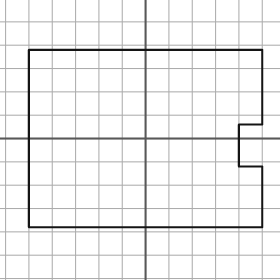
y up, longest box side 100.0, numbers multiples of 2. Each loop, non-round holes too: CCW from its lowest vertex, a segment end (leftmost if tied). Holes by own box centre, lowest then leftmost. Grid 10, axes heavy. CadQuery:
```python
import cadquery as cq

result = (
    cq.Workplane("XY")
    .moveTo(-50.0, -38.0)
    .lineTo(50.0, -38.0)
    .lineTo(50.0, -12.0)
    .lineTo(40.0, -12.0)
    .lineTo(40.0, 6.0)
    .lineTo(50.0, 6.0)
    .lineTo(50.0, 38.0)
    .lineTo(-50.0, 38.0)
    .close()
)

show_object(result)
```